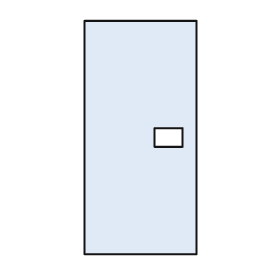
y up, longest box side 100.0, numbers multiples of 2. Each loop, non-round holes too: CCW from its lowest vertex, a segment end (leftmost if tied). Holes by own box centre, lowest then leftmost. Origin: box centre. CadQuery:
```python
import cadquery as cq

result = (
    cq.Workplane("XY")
    .moveTo(-24.0, -50.0)
    .lineTo(24.0, -50.0)
    .lineTo(24.0, 50.0)
    .lineTo(-24.0, 50.0)
    .close()
    .moveTo(6.0, -4.0)
    .lineTo(18.0, -4.0)
    .lineTo(18.0, 4.0)
    .lineTo(6.0, 4.0)
    .close()
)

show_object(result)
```